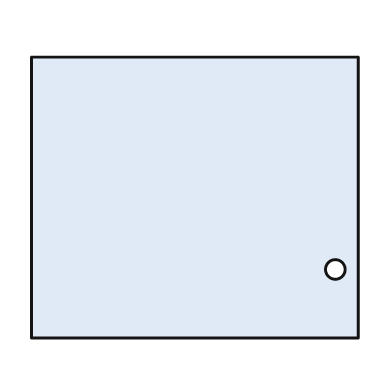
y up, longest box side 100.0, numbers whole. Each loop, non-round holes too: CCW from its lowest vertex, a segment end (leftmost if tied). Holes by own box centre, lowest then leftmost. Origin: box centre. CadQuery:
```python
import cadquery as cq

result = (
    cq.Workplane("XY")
    .moveTo(-50.0, -43.0)
    .lineTo(50.0, -43.0)
    .lineTo(50.0, 43.0)
    .lineTo(-50.0, 43.0)
    .close()
    .moveTo(43.0, -22.0)
    .circle(3.0)
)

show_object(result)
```